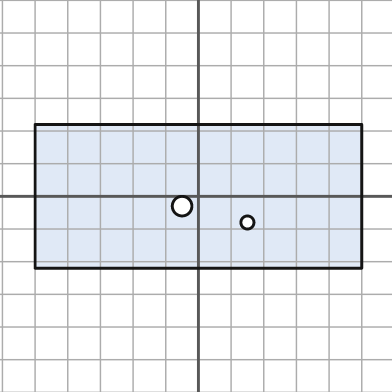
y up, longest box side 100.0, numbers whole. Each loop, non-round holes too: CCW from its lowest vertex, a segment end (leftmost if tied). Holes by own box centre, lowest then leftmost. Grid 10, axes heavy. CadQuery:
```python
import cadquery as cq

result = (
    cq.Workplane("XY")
    .moveTo(-50.0, -22.0)
    .lineTo(50.0, -22.0)
    .lineTo(50.0, 22.0)
    .lineTo(-50.0, 22.0)
    .close()
    .moveTo(15.0, -8.0)
    .circle(2.0)
    .moveTo(-5.0, -3.0)
    .circle(3.0)
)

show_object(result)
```